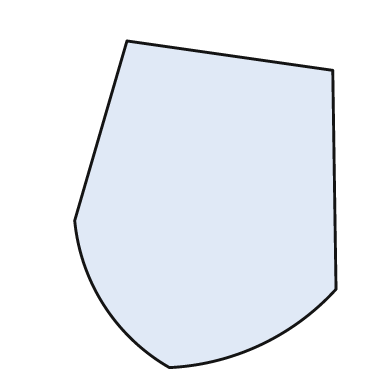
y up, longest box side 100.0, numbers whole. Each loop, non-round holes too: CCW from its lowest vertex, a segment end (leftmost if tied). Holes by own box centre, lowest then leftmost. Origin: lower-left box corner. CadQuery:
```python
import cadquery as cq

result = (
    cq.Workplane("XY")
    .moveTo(29.0, 0.0)
    .threePointArc((57.0, 7.0), (80.0, 24.0))
    .lineTo(79.0, 91.0)
    .lineTo(16.0, 100.0)
    .lineTo(0.0, 45.0)
    .threePointArc((9.0, 19.0), (29.0, 0.0))
    .close()
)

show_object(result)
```